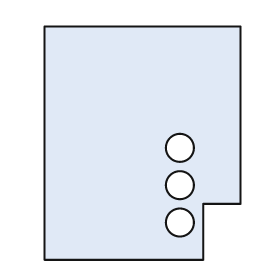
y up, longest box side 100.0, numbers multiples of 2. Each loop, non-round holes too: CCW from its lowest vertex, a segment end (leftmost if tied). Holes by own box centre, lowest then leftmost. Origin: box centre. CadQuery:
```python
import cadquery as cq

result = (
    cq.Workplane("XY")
    .moveTo(-42.0, -50.0)
    .lineTo(26.0, -50.0)
    .lineTo(26.0, -26.0)
    .lineTo(42.0, -26.0)
    .lineTo(42.0, 50.0)
    .lineTo(-42.0, 50.0)
    .close()
    .moveTo(16.0, -34.0)
    .circle(6.0)
    .moveTo(16.0, -18.0)
    .circle(6.0)
    .moveTo(16.0, -2.0)
    .circle(6.0)
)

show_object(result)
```